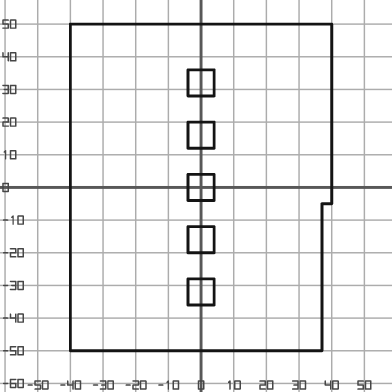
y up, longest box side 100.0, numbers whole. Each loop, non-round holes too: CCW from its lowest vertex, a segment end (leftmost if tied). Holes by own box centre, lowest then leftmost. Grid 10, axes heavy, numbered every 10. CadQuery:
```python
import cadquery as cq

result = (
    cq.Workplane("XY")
    .moveTo(-40.0, -50.0)
    .lineTo(37.0, -50.0)
    .lineTo(37.0, -5.0)
    .lineTo(40.0, -5.0)
    .lineTo(40.0, 50.0)
    .lineTo(-40.0, 50.0)
    .close()
    .moveTo(-4.0, -36.0)
    .lineTo(4.0, -36.0)
    .lineTo(4.0, -28.0)
    .lineTo(-4.0, -28.0)
    .close()
    .moveTo(-4.0, -20.0)
    .lineTo(4.0, -20.0)
    .lineTo(4.0, -12.0)
    .lineTo(-4.0, -12.0)
    .close()
    .moveTo(-4.0, -4.0)
    .lineTo(4.0, -4.0)
    .lineTo(4.0, 4.0)
    .lineTo(-4.0, 4.0)
    .close()
    .moveTo(-4.0, 12.0)
    .lineTo(4.0, 12.0)
    .lineTo(4.0, 20.0)
    .lineTo(-4.0, 20.0)
    .close()
    .moveTo(-4.0, 28.0)
    .lineTo(4.0, 28.0)
    .lineTo(4.0, 36.0)
    .lineTo(-4.0, 36.0)
    .close()
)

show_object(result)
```